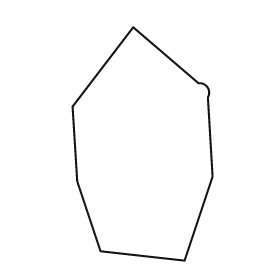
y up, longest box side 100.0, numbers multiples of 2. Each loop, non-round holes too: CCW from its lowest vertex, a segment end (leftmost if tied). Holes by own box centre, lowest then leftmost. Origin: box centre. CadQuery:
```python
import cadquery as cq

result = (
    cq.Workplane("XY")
    .moveTo(18.0, -50.0)
    .lineTo(30.0, -14.0)
    .lineTo(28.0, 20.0)
    .threePointArc((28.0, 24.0), (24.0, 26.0))
    .lineTo(-4.0, 50.0)
    .lineTo(-30.0, 16.0)
    .lineTo(-28.0, -16.0)
    .lineTo(-18.0, -46.0)
    .close()
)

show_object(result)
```